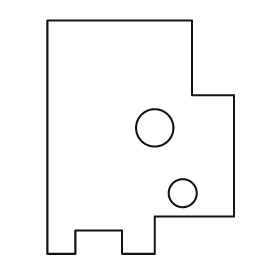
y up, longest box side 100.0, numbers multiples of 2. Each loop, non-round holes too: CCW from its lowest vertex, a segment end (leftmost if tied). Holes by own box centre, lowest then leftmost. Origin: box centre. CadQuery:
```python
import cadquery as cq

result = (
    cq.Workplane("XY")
    .moveTo(-40.0, -50.0)
    .lineTo(-28.0, -50.0)
    .lineTo(-28.0, -40.0)
    .lineTo(-8.0, -40.0)
    .lineTo(-8.0, -50.0)
    .lineTo(6.0, -50.0)
    .lineTo(6.0, -34.0)
    .lineTo(40.0, -34.0)
    .lineTo(40.0, 18.0)
    .lineTo(22.0, 18.0)
    .lineTo(22.0, 50.0)
    .lineTo(-40.0, 50.0)
    .close()
    .moveTo(18.0, -24.0)
    .circle(6.0)
    .moveTo(6.0, 4.0)
    .circle(8.0)
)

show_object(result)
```